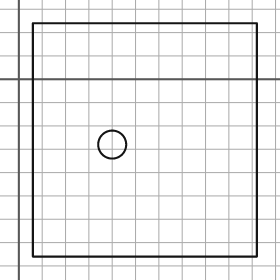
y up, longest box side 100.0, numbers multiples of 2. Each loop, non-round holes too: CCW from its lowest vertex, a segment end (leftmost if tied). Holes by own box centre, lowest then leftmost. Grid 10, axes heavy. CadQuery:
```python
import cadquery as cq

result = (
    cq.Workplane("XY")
    .moveTo(6.0, -76.0)
    .lineTo(102.0, -76.0)
    .lineTo(102.0, 24.0)
    .lineTo(6.0, 24.0)
    .close()
    .moveTo(40.0, -28.0)
    .circle(6.0)
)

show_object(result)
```